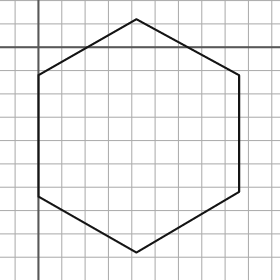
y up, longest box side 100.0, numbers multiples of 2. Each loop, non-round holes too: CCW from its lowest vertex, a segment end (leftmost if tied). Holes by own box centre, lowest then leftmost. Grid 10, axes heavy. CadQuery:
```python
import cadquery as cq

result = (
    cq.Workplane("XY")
    .moveTo(42.0, -88.0)
    .lineTo(86.0, -62.0)
    .lineTo(86.0, -12.0)
    .lineTo(42.0, 12.0)
    .lineTo(0.0, -12.0)
    .lineTo(0.0, -64.0)
    .close()
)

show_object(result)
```